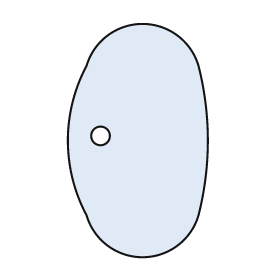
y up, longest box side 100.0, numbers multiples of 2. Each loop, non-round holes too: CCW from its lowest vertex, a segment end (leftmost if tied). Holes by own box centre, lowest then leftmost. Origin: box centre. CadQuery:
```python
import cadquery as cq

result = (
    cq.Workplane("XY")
    .moveTo(-22.0, -32.0)
    .threePointArc((2.0, -50.0), (26.0, -32.0))
    .threePointArc((30.0, 0.0), (26.0, 32.0))
    .threePointArc((2.0, 50.0), (-22.0, 32.0))
    .threePointArc((-30.0, 0.0), (-22.0, -32.0))
    .close()
    .moveTo(-16.0, 2.0)
    .circle(4.0)
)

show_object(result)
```